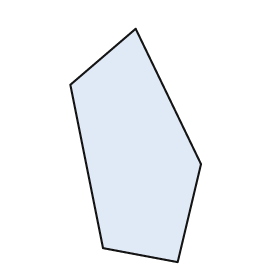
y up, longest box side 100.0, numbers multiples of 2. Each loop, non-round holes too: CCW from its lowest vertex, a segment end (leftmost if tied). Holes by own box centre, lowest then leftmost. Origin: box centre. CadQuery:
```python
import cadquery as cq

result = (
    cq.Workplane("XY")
    .moveTo(18.0, -50.0)
    .lineTo(28.0, -8.0)
    .lineTo(0.0, 50.0)
    .lineTo(-28.0, 26.0)
    .lineTo(-14.0, -44.0)
    .close()
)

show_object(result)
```